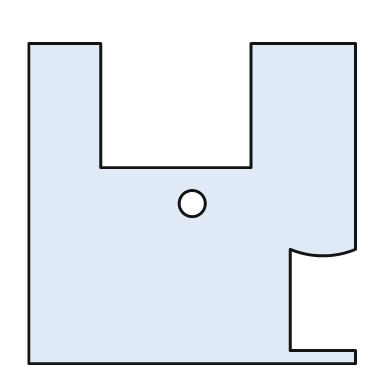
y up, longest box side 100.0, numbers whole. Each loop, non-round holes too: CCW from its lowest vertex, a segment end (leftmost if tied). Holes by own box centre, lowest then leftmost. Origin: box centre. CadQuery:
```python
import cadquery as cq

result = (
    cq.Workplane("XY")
    .moveTo(-50.0, -49.0)
    .lineTo(50.0, -49.0)
    .lineTo(50.0, -45.0)
    .lineTo(30.0, -45.0)
    .lineTo(30.0, -14.0)
    .threePointArc((40.0, -16.0), (50.0, -14.0))
    .lineTo(50.0, 49.0)
    .lineTo(18.0, 49.0)
    .lineTo(18.0, 11.0)
    .lineTo(-28.0, 11.0)
    .lineTo(-28.0, 49.0)
    .lineTo(-50.0, 49.0)
    .close()
    .moveTo(0.0, 0.0)
    .circle(4.0)
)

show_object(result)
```